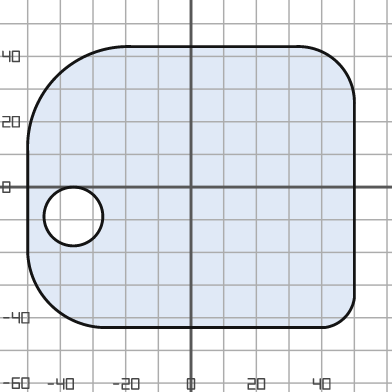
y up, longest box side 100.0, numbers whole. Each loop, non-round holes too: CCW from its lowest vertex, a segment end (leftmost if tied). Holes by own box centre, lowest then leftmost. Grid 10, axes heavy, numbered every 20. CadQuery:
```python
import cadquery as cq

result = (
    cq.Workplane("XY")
    .moveTo(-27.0, -43.0)
    .lineTo(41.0, -43.0)
    .threePointArc((47.0, -40.0), (50.0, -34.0))
    .lineTo(50.0, 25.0)
    .threePointArc((45.0, 38.0), (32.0, 43.0))
    .lineTo(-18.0, 43.0)
    .threePointArc((-41.0, 34.0), (-50.0, 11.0))
    .lineTo(-50.0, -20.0)
    .threePointArc((-43.0, -36.0), (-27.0, -43.0))
    .close()
    .moveTo(-36.0, -9.0)
    .circle(9.0)
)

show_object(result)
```